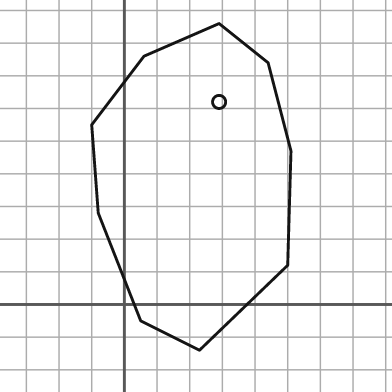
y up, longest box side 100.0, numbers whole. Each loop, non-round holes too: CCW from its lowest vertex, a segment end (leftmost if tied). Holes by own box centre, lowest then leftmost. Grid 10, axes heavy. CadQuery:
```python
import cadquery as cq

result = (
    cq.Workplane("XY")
    .moveTo(23.0, -14.0)
    .lineTo(50.0, 12.0)
    .lineTo(51.0, 47.0)
    .lineTo(44.0, 74.0)
    .lineTo(29.0, 86.0)
    .lineTo(6.0, 76.0)
    .lineTo(-10.0, 55.0)
    .lineTo(-8.0, 28.0)
    .lineTo(5.0, -5.0)
    .close()
    .moveTo(29.0, 62.0)
    .circle(2.0)
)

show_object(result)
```